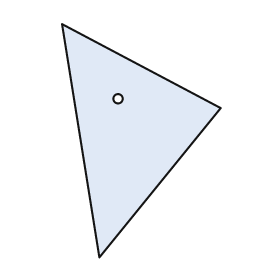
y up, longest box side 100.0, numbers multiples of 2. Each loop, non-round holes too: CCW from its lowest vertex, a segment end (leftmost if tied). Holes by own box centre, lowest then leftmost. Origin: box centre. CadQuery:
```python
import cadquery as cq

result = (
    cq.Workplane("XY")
    .moveTo(-18.0, -50.0)
    .lineTo(34.0, 14.0)
    .lineTo(-34.0, 50.0)
    .close()
    .moveTo(-10.0, 18.0)
    .circle(2.0)
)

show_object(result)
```